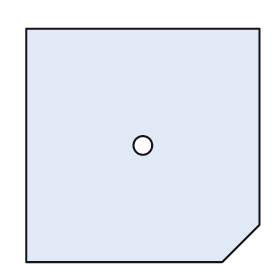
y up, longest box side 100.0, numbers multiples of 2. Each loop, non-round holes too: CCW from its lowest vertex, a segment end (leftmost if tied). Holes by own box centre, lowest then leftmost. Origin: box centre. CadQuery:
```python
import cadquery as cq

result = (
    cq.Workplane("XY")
    .moveTo(-50.0, -50.0)
    .lineTo(34.0, -50.0)
    .lineTo(50.0, -34.0)
    .lineTo(50.0, 50.0)
    .lineTo(-50.0, 50.0)
    .close()
    .moveTo(0.0, 0.0)
    .circle(4.0)
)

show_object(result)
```